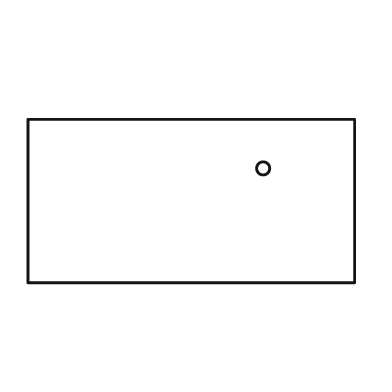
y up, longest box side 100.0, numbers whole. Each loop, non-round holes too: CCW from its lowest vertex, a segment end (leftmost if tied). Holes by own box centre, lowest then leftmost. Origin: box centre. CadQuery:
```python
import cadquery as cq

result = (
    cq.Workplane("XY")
    .moveTo(-50.0, -25.0)
    .lineTo(50.0, -25.0)
    .lineTo(50.0, 25.0)
    .lineTo(-50.0, 25.0)
    .close()
    .moveTo(22.0, 10.0)
    .circle(2.0)
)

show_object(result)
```